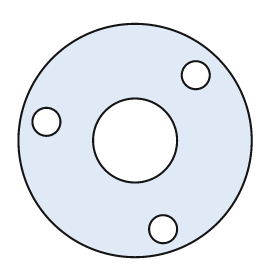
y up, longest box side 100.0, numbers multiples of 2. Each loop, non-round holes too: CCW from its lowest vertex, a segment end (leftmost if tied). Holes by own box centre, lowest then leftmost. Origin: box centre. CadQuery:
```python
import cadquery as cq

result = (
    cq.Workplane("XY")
    .moveTo(0.0, 0.0)
    .circle(50.0)
    .moveTo(12.0, -38.0)
    .circle(6.0)
    .moveTo(0.0, 0.0)
    .circle(18.0)
    .moveTo(-38.0, 8.0)
    .circle(6.0)
    .moveTo(26.0, 28.0)
    .circle(6.0)
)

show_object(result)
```